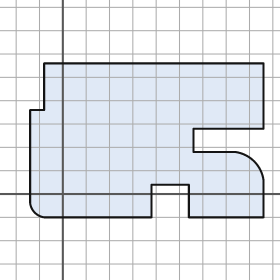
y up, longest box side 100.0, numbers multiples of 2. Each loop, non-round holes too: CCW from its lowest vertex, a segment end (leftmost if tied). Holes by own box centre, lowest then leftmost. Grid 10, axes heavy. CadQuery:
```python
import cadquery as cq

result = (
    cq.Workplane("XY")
    .moveTo(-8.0, -10.0)
    .lineTo(38.0, -10.0)
    .lineTo(38.0, 4.0)
    .lineTo(54.0, 4.0)
    .lineTo(54.0, -10.0)
    .lineTo(86.0, -10.0)
    .lineTo(86.0, 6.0)
    .threePointArc((82.0, 14.0), (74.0, 18.0))
    .lineTo(56.0, 18.0)
    .lineTo(56.0, 28.0)
    .lineTo(86.0, 28.0)
    .lineTo(86.0, 56.0)
    .lineTo(-8.0, 56.0)
    .lineTo(-8.0, 36.0)
    .lineTo(-14.0, 36.0)
    .lineTo(-14.0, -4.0)
    .threePointArc((-12.0, -8.0), (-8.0, -10.0))
    .close()
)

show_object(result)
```